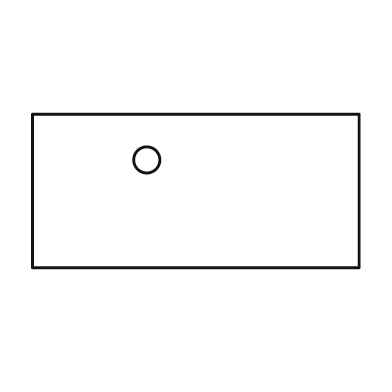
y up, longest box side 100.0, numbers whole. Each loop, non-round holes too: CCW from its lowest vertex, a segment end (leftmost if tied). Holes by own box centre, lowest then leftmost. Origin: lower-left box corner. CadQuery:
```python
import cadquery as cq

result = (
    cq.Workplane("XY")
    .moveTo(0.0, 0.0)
    .lineTo(100.0, 0.0)
    .lineTo(100.0, 47.0)
    .lineTo(0.0, 47.0)
    .close()
    .moveTo(35.0, 33.0)
    .circle(4.0)
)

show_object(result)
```